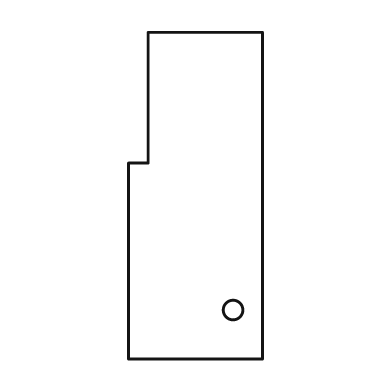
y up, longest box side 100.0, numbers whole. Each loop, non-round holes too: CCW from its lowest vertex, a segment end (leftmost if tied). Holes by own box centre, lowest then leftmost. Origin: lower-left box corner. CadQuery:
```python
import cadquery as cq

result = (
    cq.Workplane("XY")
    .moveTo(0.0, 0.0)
    .lineTo(41.0, 0.0)
    .lineTo(41.0, 100.0)
    .lineTo(6.0, 100.0)
    .lineTo(6.0, 60.0)
    .lineTo(0.0, 60.0)
    .close()
    .moveTo(32.0, 15.0)
    .circle(3.0)
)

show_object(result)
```